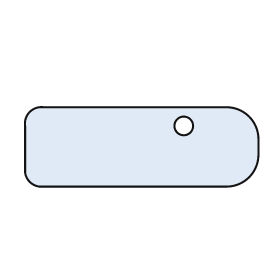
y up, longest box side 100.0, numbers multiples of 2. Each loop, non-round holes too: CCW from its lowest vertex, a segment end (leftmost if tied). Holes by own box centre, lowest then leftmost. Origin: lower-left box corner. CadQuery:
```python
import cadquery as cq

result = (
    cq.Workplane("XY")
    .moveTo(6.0, 0.0)
    .lineTo(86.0, 0.0)
    .threePointArc((96.0, 4.0), (100.0, 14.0))
    .lineTo(100.0, 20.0)
    .threePointArc((96.0, 30.0), (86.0, 34.0))
    .lineTo(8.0, 34.0)
    .threePointArc((2.0, 32.0), (0.0, 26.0))
    .lineTo(0.0, 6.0)
    .threePointArc((2.0, 2.0), (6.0, 0.0))
    .close()
    .moveTo(68.0, 26.0)
    .circle(4.0)
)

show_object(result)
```